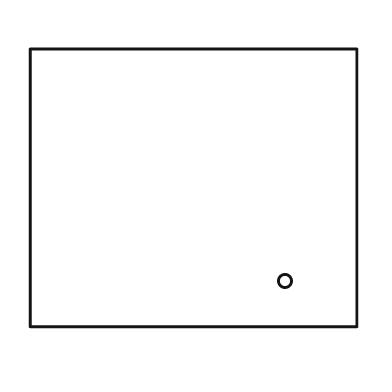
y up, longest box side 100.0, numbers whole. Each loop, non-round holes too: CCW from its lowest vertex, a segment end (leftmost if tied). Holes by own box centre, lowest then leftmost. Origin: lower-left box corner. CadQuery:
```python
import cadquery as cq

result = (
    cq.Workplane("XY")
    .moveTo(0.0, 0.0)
    .lineTo(100.0, 0.0)
    .lineTo(100.0, 85.0)
    .lineTo(0.0, 85.0)
    .close()
    .moveTo(78.0, 14.0)
    .circle(2.0)
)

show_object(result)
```